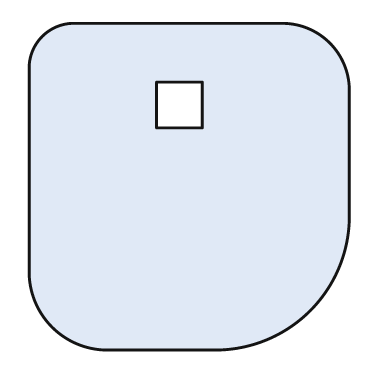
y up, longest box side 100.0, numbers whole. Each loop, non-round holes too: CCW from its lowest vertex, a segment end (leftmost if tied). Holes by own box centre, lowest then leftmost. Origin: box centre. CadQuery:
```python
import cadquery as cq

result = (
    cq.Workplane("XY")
    .moveTo(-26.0, -50.0)
    .lineTo(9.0, -50.0)
    .threePointArc((37.0, -38.0), (49.0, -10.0))
    .lineTo(49.0, 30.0)
    .threePointArc((43.0, 44.0), (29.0, 50.0))
    .lineTo(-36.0, 50.0)
    .threePointArc((-45.0, 46.0), (-49.0, 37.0))
    .lineTo(-49.0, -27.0)
    .threePointArc((-42.0, -43.0), (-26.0, -50.0))
    .close()
    .moveTo(-10.0, 18.0)
    .lineTo(4.0, 18.0)
    .lineTo(4.0, 32.0)
    .lineTo(-10.0, 32.0)
    .close()
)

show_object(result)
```